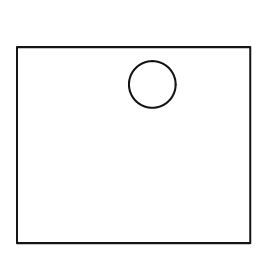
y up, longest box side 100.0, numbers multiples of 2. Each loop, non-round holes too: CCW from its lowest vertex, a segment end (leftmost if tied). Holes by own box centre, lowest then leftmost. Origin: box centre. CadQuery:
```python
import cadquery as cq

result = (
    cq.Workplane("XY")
    .moveTo(-50.0, -42.0)
    .lineTo(50.0, -42.0)
    .lineTo(50.0, 42.0)
    .lineTo(-50.0, 42.0)
    .close()
    .moveTo(8.0, 26.0)
    .circle(10.0)
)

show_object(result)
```